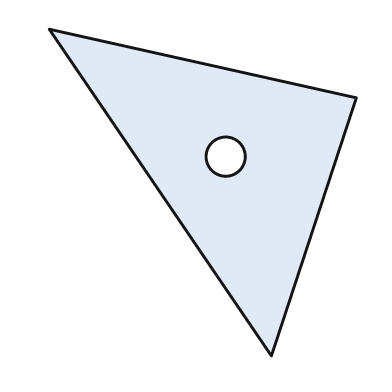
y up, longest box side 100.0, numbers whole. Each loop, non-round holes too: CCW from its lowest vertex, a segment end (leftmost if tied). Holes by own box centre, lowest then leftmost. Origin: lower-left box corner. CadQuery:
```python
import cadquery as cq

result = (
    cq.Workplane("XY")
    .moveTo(68.0, 0.0)
    .lineTo(94.0, 79.0)
    .lineTo(0.0, 100.0)
    .close()
    .moveTo(54.0, 61.0)
    .circle(6.0)
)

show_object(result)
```